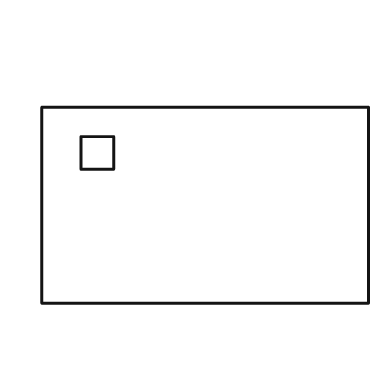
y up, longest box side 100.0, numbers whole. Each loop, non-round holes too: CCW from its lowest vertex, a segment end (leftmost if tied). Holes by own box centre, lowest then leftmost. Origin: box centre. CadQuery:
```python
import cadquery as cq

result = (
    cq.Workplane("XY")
    .moveTo(-50.0, -30.0)
    .lineTo(50.0, -30.0)
    .lineTo(50.0, 30.0)
    .lineTo(-50.0, 30.0)
    .close()
    .moveTo(-38.0, 11.0)
    .lineTo(-28.0, 11.0)
    .lineTo(-28.0, 21.0)
    .lineTo(-38.0, 21.0)
    .close()
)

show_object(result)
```